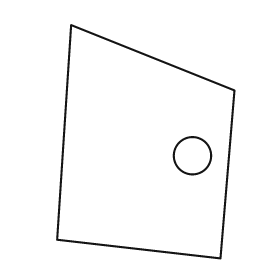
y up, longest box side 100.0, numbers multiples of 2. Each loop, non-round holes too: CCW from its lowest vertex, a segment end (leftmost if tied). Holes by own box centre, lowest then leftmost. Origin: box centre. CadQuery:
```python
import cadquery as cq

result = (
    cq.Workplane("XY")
    .moveTo(32.0, -50.0)
    .lineTo(38.0, 22.0)
    .lineTo(-32.0, 50.0)
    .lineTo(-38.0, -42.0)
    .close()
    .moveTo(20.0, -6.0)
    .circle(8.0)
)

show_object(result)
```